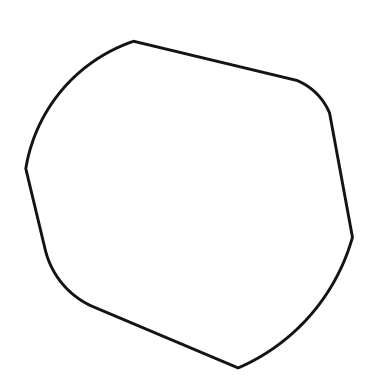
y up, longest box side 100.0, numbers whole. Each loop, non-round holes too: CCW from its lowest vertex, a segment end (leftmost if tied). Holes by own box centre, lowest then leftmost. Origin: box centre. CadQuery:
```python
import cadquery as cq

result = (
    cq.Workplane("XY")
    .moveTo(15.0, -50.0)
    .threePointArc((37.0, -34.0), (50.0, -10.0))
    .lineTo(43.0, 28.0)
    .threePointArc((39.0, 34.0), (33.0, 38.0))
    .lineTo(-17.0, 50.0)
    .threePointArc((-39.0, 35.0), (-50.0, 11.0))
    .lineTo(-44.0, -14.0)
    .threePointArc((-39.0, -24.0), (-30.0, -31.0))
    .close()
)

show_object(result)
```